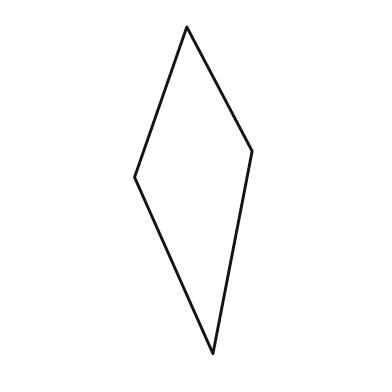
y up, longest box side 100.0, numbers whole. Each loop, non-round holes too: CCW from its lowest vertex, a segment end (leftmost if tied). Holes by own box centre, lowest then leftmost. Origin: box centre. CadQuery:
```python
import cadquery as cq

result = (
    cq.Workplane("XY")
    .moveTo(6.0, -50.0)
    .lineTo(18.0, 12.0)
    .lineTo(-2.0, 50.0)
    .lineTo(-18.0, 4.0)
    .close()
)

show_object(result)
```